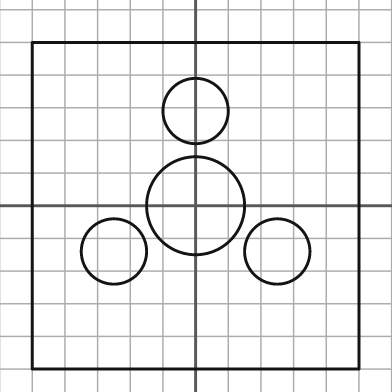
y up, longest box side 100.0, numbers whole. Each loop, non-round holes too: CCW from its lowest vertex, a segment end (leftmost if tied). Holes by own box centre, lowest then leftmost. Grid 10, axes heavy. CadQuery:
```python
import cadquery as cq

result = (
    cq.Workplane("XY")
    .moveTo(-50.0, -50.0)
    .lineTo(50.0, -50.0)
    .lineTo(50.0, 50.0)
    .lineTo(-50.0, 50.0)
    .close()
    .moveTo(-25.0, -14.0)
    .circle(10.0)
    .moveTo(25.0, -14.0)
    .circle(10.0)
    .moveTo(0.0, 0.0)
    .circle(15.0)
    .moveTo(0.0, 29.0)
    .circle(10.0)
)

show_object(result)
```